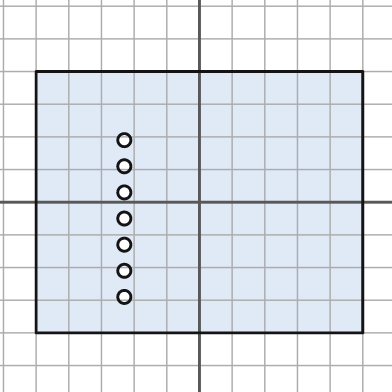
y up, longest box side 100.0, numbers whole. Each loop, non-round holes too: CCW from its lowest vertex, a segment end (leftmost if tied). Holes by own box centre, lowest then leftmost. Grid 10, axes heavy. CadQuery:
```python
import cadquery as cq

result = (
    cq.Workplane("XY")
    .moveTo(-50.0, -40.0)
    .lineTo(50.0, -40.0)
    .lineTo(50.0, 40.0)
    .lineTo(-50.0, 40.0)
    .close()
    .moveTo(-23.0, -29.0)
    .circle(2.0)
    .moveTo(-23.0, -21.0)
    .circle(2.0)
    .moveTo(-23.0, -13.0)
    .circle(2.0)
    .moveTo(-23.0, -5.0)
    .circle(2.0)
    .moveTo(-23.0, 3.0)
    .circle(2.0)
    .moveTo(-23.0, 11.0)
    .circle(2.0)
    .moveTo(-23.0, 19.0)
    .circle(2.0)
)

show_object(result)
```